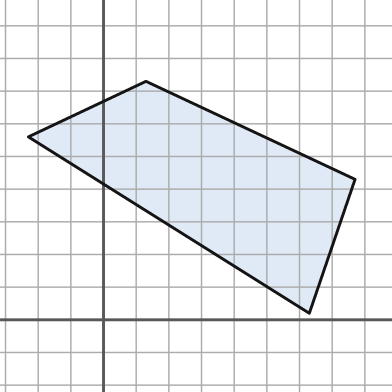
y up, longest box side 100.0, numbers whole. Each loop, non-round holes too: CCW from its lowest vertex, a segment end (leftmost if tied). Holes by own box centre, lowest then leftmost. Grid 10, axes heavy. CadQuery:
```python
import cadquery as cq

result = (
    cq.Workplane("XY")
    .moveTo(63.0, 2.0)
    .lineTo(77.0, 43.0)
    .lineTo(13.0, 73.0)
    .lineTo(-23.0, 56.0)
    .close()
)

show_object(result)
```